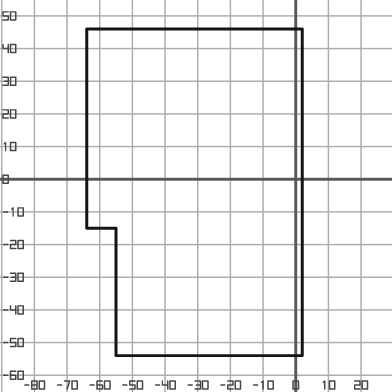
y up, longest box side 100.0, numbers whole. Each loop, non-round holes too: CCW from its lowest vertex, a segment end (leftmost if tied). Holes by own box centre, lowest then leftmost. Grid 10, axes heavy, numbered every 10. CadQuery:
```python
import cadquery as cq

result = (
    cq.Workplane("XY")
    .moveTo(-55.0, -54.0)
    .lineTo(2.0, -54.0)
    .lineTo(2.0, 46.0)
    .lineTo(-64.0, 46.0)
    .lineTo(-64.0, -15.0)
    .lineTo(-55.0, -15.0)
    .close()
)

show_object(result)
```